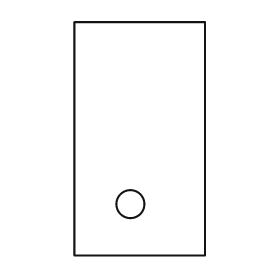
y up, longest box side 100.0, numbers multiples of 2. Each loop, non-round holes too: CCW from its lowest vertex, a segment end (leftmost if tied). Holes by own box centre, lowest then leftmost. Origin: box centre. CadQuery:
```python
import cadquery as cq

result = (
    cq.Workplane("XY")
    .moveTo(-28.0, -50.0)
    .lineTo(28.0, -50.0)
    .lineTo(28.0, 50.0)
    .lineTo(-28.0, 50.0)
    .close()
    .moveTo(-4.0, -28.0)
    .circle(6.0)
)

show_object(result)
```